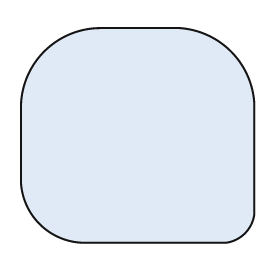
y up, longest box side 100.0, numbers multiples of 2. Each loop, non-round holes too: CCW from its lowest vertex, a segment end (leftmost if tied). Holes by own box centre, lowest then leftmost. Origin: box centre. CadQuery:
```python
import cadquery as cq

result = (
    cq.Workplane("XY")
    .moveTo(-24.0, -46.0)
    .lineTo(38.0, -46.0)
    .threePointArc((46.0, -42.0), (50.0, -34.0))
    .lineTo(50.0, 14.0)
    .threePointArc((40.0, 36.0), (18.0, 46.0))
    .lineTo(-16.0, 46.0)
    .threePointArc((-40.0, 36.0), (-50.0, 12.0))
    .lineTo(-50.0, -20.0)
    .threePointArc((-42.0, -38.0), (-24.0, -46.0))
    .close()
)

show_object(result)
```